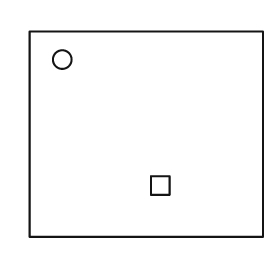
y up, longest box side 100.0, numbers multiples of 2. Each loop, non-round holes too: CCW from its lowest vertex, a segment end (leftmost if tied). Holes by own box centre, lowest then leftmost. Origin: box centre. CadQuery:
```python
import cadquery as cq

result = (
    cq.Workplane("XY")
    .moveTo(-50.0, -44.0)
    .lineTo(50.0, -44.0)
    .lineTo(50.0, 44.0)
    .lineTo(-50.0, 44.0)
    .close()
    .moveTo(2.0, -26.0)
    .lineTo(10.0, -26.0)
    .lineTo(10.0, -18.0)
    .lineTo(2.0, -18.0)
    .close()
    .moveTo(-36.0, 32.0)
    .circle(4.0)
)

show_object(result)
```